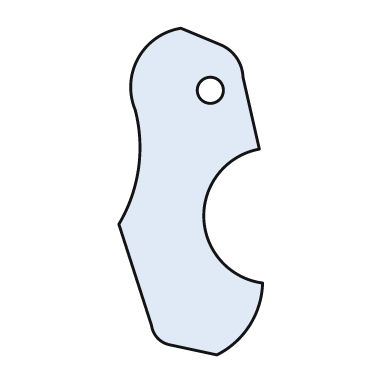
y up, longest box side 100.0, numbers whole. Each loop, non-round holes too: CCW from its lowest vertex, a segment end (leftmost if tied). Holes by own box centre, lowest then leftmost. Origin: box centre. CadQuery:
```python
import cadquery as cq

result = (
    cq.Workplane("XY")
    .moveTo(8.0, -50.0)
    .threePointArc((18.0, -41.0), (22.0, -28.0))
    .threePointArc((4.0, -8.0), (21.0, 13.0))
    .lineTo(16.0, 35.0)
    .threePointArc((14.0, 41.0), (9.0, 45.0))
    .lineTo(-3.0, 50.0)
    .threePointArc((-16.0, 41.0), (-17.0, 25.0))
    .threePointArc((-16.0, 7.0), (-22.0, -10.0))
    .lineTo(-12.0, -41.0)
    .threePointArc((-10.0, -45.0), (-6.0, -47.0))
    .close()
    .moveTo(6.0, 31.0)
    .circle(4.0)
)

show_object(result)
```